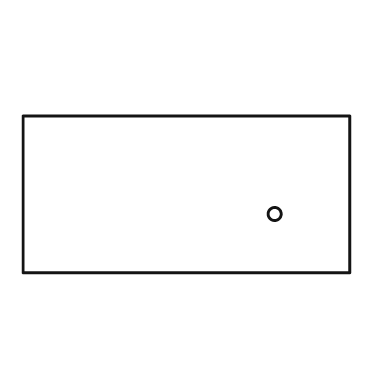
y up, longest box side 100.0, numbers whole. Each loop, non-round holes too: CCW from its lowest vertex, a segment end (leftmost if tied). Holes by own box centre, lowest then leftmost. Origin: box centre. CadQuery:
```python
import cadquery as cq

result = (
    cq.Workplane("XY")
    .moveTo(-50.0, -24.0)
    .lineTo(50.0, -24.0)
    .lineTo(50.0, 24.0)
    .lineTo(-50.0, 24.0)
    .close()
    .moveTo(27.0, -6.0)
    .circle(2.0)
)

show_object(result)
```